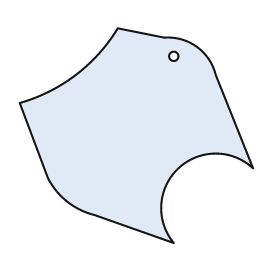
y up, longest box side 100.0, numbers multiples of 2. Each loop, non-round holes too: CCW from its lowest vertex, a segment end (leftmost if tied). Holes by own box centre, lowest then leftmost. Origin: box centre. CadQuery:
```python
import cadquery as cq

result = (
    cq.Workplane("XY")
    .moveTo(16.0, -46.0)
    .threePointArc((18.0, -14.0), (50.0, -14.0))
    .lineTo(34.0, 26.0)
    .threePointArc((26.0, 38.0), (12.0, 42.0))
    .lineTo(-8.0, 46.0)
    .threePointArc((-26.0, 26.0), (-50.0, 14.0))
    .lineTo(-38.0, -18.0)
    .threePointArc((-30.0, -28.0), (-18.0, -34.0))
    .close()
    .moveTo(16.0, 34.0)
    .circle(2.0)
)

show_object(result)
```